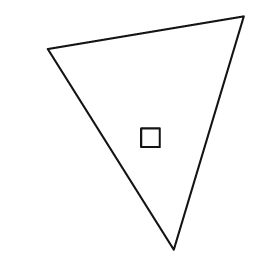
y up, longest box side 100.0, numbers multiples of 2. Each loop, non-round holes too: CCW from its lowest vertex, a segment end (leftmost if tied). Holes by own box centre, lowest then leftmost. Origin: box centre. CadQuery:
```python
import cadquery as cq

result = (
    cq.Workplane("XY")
    .moveTo(12.0, -50.0)
    .lineTo(42.0, 50.0)
    .lineTo(-42.0, 36.0)
    .close()
    .moveTo(-2.0, -6.0)
    .lineTo(6.0, -6.0)
    .lineTo(6.0, 2.0)
    .lineTo(-2.0, 2.0)
    .close()
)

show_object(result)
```